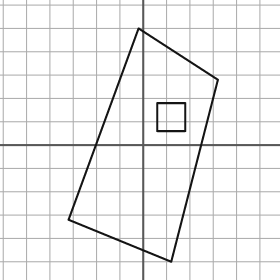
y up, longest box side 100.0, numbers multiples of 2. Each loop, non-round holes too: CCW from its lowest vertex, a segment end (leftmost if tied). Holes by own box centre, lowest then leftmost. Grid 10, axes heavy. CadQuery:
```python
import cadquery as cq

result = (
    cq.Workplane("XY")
    .moveTo(12.0, -50.0)
    .lineTo(32.0, 28.0)
    .lineTo(-2.0, 50.0)
    .lineTo(-32.0, -32.0)
    .close()
    .moveTo(6.0, 6.0)
    .lineTo(18.0, 6.0)
    .lineTo(18.0, 18.0)
    .lineTo(6.0, 18.0)
    .close()
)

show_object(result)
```